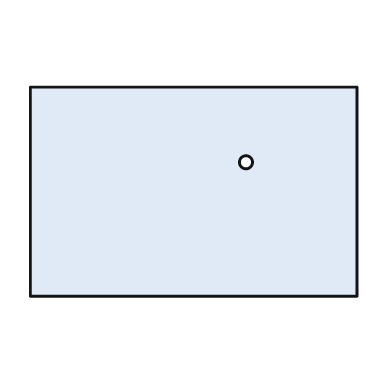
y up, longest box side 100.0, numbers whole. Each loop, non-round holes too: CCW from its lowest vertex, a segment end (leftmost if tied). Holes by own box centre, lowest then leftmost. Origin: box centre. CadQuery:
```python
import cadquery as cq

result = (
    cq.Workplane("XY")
    .moveTo(-50.0, -32.0)
    .lineTo(50.0, -32.0)
    .lineTo(50.0, 32.0)
    .lineTo(-50.0, 32.0)
    .close()
    .moveTo(16.0, 9.0)
    .circle(2.0)
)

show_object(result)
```